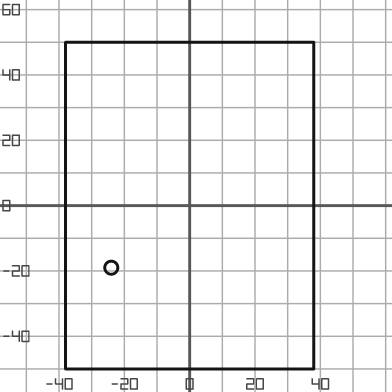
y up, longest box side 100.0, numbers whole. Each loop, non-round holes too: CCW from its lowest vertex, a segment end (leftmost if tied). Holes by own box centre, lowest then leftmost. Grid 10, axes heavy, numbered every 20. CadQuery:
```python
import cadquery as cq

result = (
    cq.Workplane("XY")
    .moveTo(-38.0, -50.0)
    .lineTo(38.0, -50.0)
    .lineTo(38.0, 50.0)
    .lineTo(-38.0, 50.0)
    .close()
    .moveTo(-24.0, -19.0)
    .circle(2.0)
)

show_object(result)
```